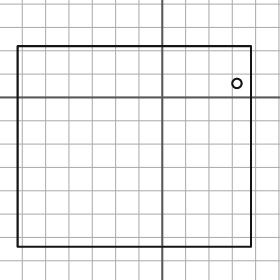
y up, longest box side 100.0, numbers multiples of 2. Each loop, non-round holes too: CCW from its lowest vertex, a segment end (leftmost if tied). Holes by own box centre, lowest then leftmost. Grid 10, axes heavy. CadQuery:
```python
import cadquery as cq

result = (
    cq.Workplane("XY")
    .moveTo(-62.0, -64.0)
    .lineTo(38.0, -64.0)
    .lineTo(38.0, 22.0)
    .lineTo(-62.0, 22.0)
    .close()
    .moveTo(32.0, 6.0)
    .circle(2.0)
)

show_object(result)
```